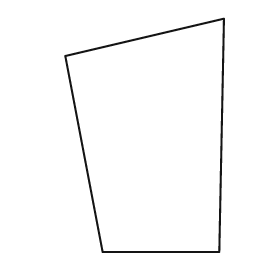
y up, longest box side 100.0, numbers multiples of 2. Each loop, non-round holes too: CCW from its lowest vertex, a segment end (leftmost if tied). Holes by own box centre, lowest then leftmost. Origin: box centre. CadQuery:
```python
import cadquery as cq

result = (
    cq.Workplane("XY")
    .moveTo(-18.0, -50.0)
    .lineTo(32.0, -50.0)
    .lineTo(34.0, 50.0)
    .lineTo(-34.0, 34.0)
    .close()
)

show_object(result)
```